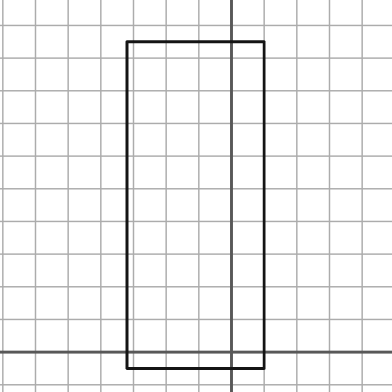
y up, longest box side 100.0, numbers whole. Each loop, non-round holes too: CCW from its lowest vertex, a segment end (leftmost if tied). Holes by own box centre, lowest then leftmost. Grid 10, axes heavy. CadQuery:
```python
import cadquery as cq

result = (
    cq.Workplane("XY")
    .moveTo(-32.0, -5.0)
    .lineTo(10.0, -5.0)
    .lineTo(10.0, 95.0)
    .lineTo(-32.0, 95.0)
    .close()
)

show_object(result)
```